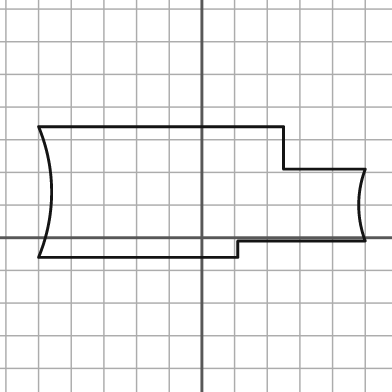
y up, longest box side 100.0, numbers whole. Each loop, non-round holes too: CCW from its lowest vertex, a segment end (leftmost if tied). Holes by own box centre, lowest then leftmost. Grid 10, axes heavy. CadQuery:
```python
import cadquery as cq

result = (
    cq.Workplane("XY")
    .moveTo(-50.0, -6.0)
    .lineTo(11.0, -6.0)
    .lineTo(11.0, -1.0)
    .lineTo(50.0, -1.0)
    .threePointArc((48.0, 10.0), (50.0, 21.0))
    .lineTo(25.0, 21.0)
    .lineTo(25.0, 34.0)
    .lineTo(-50.0, 34.0)
    .threePointArc((-46.0, 14.0), (-50.0, -6.0))
    .close()
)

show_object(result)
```